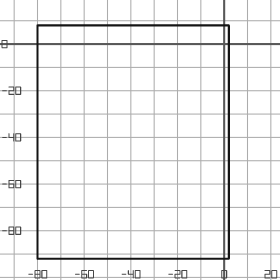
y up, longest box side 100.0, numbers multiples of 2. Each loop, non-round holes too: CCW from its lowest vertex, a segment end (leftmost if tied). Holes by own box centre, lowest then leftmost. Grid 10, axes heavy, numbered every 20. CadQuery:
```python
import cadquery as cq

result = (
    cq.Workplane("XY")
    .moveTo(-80.0, -92.0)
    .lineTo(2.0, -92.0)
    .lineTo(2.0, 8.0)
    .lineTo(-80.0, 8.0)
    .close()
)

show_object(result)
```